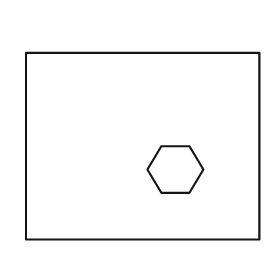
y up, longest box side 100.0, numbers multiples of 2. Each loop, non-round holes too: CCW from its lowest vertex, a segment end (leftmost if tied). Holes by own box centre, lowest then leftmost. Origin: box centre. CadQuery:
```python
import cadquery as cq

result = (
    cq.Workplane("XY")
    .moveTo(-50.0, -40.0)
    .lineTo(50.0, -40.0)
    .lineTo(50.0, 40.0)
    .lineTo(-50.0, 40.0)
    .close()
    .moveTo(8.0, -20.0)
    .lineTo(20.0, -20.0)
    .lineTo(26.0, -10.0)
    .lineTo(20.0, 0.0)
    .lineTo(8.0, 0.0)
    .lineTo(2.0, -10.0)
    .close()
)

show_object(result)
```